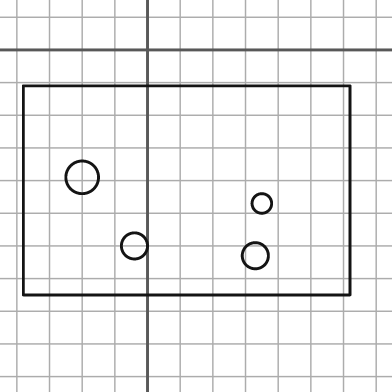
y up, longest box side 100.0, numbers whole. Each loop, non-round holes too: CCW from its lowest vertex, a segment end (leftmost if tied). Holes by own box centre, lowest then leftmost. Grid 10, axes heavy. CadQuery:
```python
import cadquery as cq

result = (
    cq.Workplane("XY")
    .moveTo(-38.0, -75.0)
    .lineTo(62.0, -75.0)
    .lineTo(62.0, -11.0)
    .lineTo(-38.0, -11.0)
    .close()
    .moveTo(33.0, -63.0)
    .circle(4.0)
    .moveTo(-4.0, -60.0)
    .circle(4.0)
    .moveTo(35.0, -47.0)
    .circle(3.0)
    .moveTo(-20.0, -39.0)
    .circle(5.0)
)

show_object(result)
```